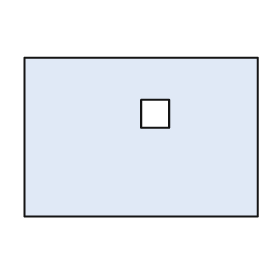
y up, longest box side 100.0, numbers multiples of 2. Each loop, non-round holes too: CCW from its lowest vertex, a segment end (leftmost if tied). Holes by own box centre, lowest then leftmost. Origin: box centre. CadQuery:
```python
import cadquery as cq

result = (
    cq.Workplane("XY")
    .moveTo(-50.0, -34.0)
    .lineTo(50.0, -34.0)
    .lineTo(50.0, 34.0)
    .lineTo(-50.0, 34.0)
    .close()
    .moveTo(0.0, 4.0)
    .lineTo(12.0, 4.0)
    .lineTo(12.0, 16.0)
    .lineTo(0.0, 16.0)
    .close()
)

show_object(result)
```